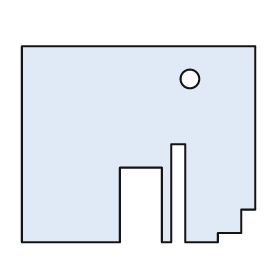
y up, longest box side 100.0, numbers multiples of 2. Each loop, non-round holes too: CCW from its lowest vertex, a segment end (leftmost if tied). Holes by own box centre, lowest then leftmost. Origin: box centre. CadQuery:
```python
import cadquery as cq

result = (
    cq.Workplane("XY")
    .moveTo(-50.0, -42.0)
    .lineTo(-8.0, -42.0)
    .lineTo(-8.0, -10.0)
    .lineTo(10.0, -10.0)
    .lineTo(10.0, -42.0)
    .lineTo(14.0, -42.0)
    .lineTo(14.0, 0.0)
    .lineTo(20.0, 0.0)
    .lineTo(20.0, -42.0)
    .lineTo(34.0, -42.0)
    .lineTo(34.0, -38.0)
    .lineTo(44.0, -38.0)
    .lineTo(44.0, -28.0)
    .lineTo(50.0, -28.0)
    .lineTo(50.0, 42.0)
    .lineTo(-50.0, 42.0)
    .close()
    .moveTo(22.0, 28.0)
    .circle(4.0)
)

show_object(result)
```